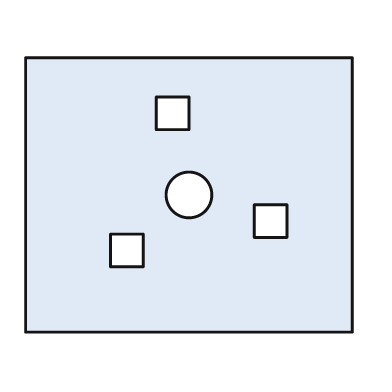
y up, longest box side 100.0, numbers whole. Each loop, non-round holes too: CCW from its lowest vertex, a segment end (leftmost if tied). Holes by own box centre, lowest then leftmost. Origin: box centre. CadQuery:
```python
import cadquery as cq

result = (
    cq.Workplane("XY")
    .moveTo(-50.0, -42.0)
    .lineTo(50.0, -42.0)
    .lineTo(50.0, 42.0)
    .lineTo(-50.0, 42.0)
    .close()
    .moveTo(-24.0, -22.0)
    .lineTo(-14.0, -22.0)
    .lineTo(-14.0, -12.0)
    .lineTo(-24.0, -12.0)
    .close()
    .moveTo(20.0, -13.0)
    .lineTo(30.0, -13.0)
    .lineTo(30.0, -3.0)
    .lineTo(20.0, -3.0)
    .close()
    .moveTo(0.0, 0.0)
    .circle(7.0)
    .moveTo(-10.0, 20.0)
    .lineTo(0.0, 20.0)
    .lineTo(0.0, 30.0)
    .lineTo(-10.0, 30.0)
    .close()
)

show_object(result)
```